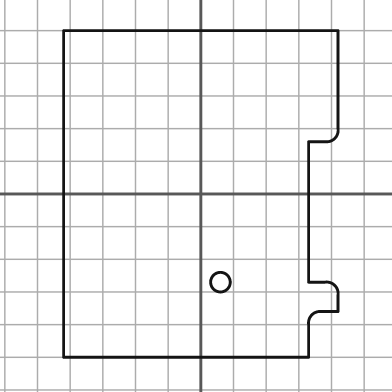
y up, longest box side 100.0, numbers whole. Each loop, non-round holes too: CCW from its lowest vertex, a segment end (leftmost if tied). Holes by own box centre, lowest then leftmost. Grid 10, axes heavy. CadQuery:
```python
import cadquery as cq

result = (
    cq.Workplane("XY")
    .moveTo(-42.0, -50.0)
    .lineTo(33.0, -50.0)
    .lineTo(33.0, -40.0)
    .threePointArc((34.0, -37.0), (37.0, -36.0))
    .lineTo(42.0, -36.0)
    .lineTo(42.0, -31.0)
    .threePointArc((41.0, -28.0), (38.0, -27.0))
    .lineTo(33.0, -27.0)
    .lineTo(33.0, 16.0)
    .lineTo(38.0, 16.0)
    .threePointArc((41.0, 17.0), (42.0, 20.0))
    .lineTo(42.0, 50.0)
    .lineTo(-42.0, 50.0)
    .close()
    .moveTo(6.0, -27.0)
    .circle(3.0)
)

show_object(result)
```